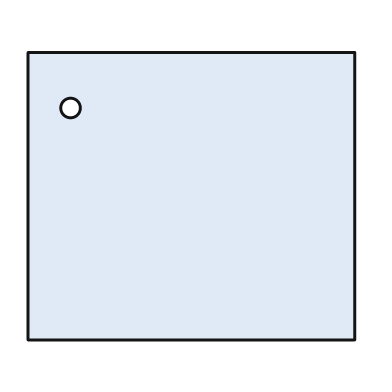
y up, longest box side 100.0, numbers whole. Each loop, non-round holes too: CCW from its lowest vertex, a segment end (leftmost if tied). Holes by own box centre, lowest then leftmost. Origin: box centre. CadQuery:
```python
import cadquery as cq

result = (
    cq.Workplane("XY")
    .moveTo(-50.0, -44.0)
    .lineTo(50.0, -44.0)
    .lineTo(50.0, 44.0)
    .lineTo(-50.0, 44.0)
    .close()
    .moveTo(-37.0, 27.0)
    .circle(3.0)
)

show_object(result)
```